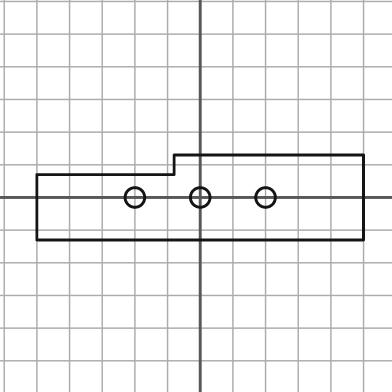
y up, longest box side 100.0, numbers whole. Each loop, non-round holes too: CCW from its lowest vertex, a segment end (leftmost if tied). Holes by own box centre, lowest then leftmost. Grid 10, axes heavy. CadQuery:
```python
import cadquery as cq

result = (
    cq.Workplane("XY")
    .moveTo(-50.0, -13.0)
    .lineTo(50.0, -13.0)
    .lineTo(50.0, 13.0)
    .lineTo(-8.0, 13.0)
    .lineTo(-8.0, 7.0)
    .lineTo(-50.0, 7.0)
    .close()
    .moveTo(-20.0, 0.0)
    .circle(3.0)
    .moveTo(0.0, 0.0)
    .circle(3.0)
    .moveTo(20.0, 0.0)
    .circle(3.0)
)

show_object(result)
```